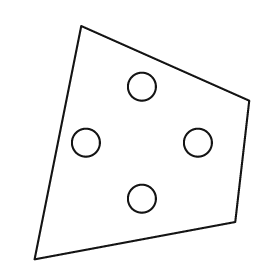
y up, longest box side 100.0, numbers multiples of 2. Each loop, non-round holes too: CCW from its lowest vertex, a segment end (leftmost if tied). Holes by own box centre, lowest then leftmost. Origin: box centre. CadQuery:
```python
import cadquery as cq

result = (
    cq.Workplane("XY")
    .moveTo(-46.0, -50.0)
    .lineTo(40.0, -34.0)
    .lineTo(46.0, 18.0)
    .lineTo(-26.0, 50.0)
    .close()
    .moveTo(0.0, -24.0)
    .circle(6.0)
    .moveTo(-24.0, 0.0)
    .circle(6.0)
    .moveTo(24.0, 0.0)
    .circle(6.0)
    .moveTo(0.0, 24.0)
    .circle(6.0)
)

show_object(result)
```